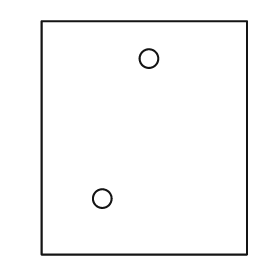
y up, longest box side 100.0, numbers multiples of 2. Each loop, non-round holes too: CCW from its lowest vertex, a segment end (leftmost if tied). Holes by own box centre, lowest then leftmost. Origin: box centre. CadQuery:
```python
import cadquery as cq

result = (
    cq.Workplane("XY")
    .moveTo(-44.0, -50.0)
    .lineTo(44.0, -50.0)
    .lineTo(44.0, 50.0)
    .lineTo(-44.0, 50.0)
    .close()
    .moveTo(-18.0, -26.0)
    .circle(4.0)
    .moveTo(2.0, 34.0)
    .circle(4.0)
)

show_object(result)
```